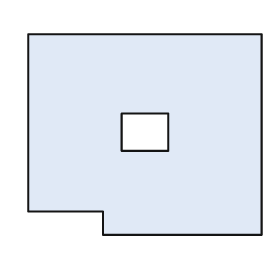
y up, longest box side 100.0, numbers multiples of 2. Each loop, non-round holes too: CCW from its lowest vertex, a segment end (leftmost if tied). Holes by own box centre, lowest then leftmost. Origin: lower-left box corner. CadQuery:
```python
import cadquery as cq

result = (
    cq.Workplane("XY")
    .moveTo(32.0, 0.0)
    .lineTo(100.0, 0.0)
    .lineTo(100.0, 86.0)
    .lineTo(0.0, 86.0)
    .lineTo(0.0, 10.0)
    .lineTo(32.0, 10.0)
    .close()
    .moveTo(40.0, 36.0)
    .lineTo(60.0, 36.0)
    .lineTo(60.0, 52.0)
    .lineTo(40.0, 52.0)
    .close()
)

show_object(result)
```